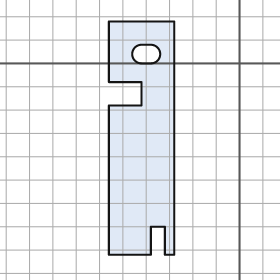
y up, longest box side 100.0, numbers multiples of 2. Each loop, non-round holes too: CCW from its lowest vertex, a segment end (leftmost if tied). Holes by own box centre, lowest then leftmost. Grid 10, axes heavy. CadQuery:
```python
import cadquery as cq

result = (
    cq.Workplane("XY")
    .moveTo(-56.0, -82.0)
    .lineTo(-38.0, -82.0)
    .lineTo(-38.0, -70.0)
    .lineTo(-32.0, -70.0)
    .lineTo(-32.0, -82.0)
    .lineTo(-28.0, -82.0)
    .lineTo(-28.0, 18.0)
    .lineTo(-56.0, 18.0)
    .lineTo(-56.0, -8.0)
    .lineTo(-42.0, -8.0)
    .lineTo(-42.0, -18.0)
    .lineTo(-56.0, -18.0)
    .close()
    .moveTo(-42.0, 0.0)
    .lineTo(-38.0, 0.0)
    .threePointArc((-34.0, 4.0), (-38.0, 8.0))
    .lineTo(-42.0, 8.0)
    .threePointArc((-46.0, 4.0), (-42.0, 0.0))
    .close()
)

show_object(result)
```